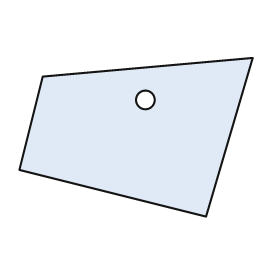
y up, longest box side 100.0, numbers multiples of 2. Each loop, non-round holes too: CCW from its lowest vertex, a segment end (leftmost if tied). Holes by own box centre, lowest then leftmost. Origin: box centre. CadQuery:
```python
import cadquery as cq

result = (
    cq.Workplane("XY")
    .moveTo(30.0, -34.0)
    .lineTo(50.0, 34.0)
    .lineTo(-40.0, 26.0)
    .lineTo(-50.0, -14.0)
    .close()
    .moveTo(4.0, 16.0)
    .circle(4.0)
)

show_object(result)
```